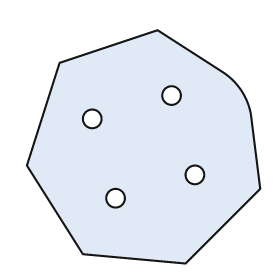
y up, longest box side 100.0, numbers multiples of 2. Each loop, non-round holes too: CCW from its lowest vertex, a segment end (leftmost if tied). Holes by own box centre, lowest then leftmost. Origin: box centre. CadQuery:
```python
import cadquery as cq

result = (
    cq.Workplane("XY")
    .moveTo(18.0, -50.0)
    .lineTo(50.0, -18.0)
    .lineTo(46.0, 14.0)
    .threePointArc((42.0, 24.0), (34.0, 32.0))
    .lineTo(6.0, 50.0)
    .lineTo(-36.0, 36.0)
    .lineTo(-50.0, -8.0)
    .lineTo(-26.0, -46.0)
    .close()
    .moveTo(-12.0, -22.0)
    .circle(4.0)
    .moveTo(22.0, -12.0)
    .circle(4.0)
    .moveTo(-22.0, 12.0)
    .circle(4.0)
    .moveTo(12.0, 22.0)
    .circle(4.0)
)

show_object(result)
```